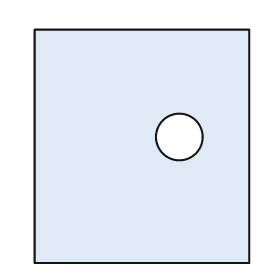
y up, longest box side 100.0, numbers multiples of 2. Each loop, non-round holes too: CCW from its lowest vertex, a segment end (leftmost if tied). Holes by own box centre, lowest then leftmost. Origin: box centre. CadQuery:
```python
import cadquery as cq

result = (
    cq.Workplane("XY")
    .moveTo(-46.0, -50.0)
    .lineTo(46.0, -50.0)
    .lineTo(46.0, 50.0)
    .lineTo(-46.0, 50.0)
    .close()
    .moveTo(16.0, 4.0)
    .circle(10.0)
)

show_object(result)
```